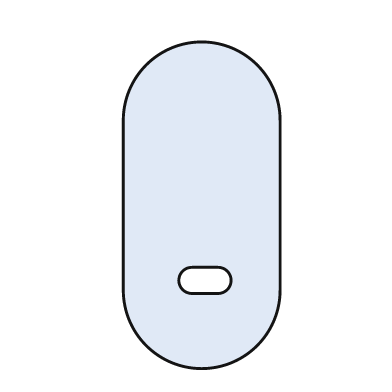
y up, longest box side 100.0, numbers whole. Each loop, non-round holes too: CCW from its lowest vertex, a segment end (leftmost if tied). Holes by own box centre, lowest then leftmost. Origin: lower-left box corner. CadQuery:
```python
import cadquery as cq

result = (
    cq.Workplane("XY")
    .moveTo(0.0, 24.0)
    .threePointArc((24.0, 0.0), (48.0, 24.0))
    .lineTo(48.0, 76.0)
    .threePointArc((24.0, 100.0), (0.0, 76.0))
    .close()
    .moveTo(21.0, 23.0)
    .lineTo(29.0, 23.0)
    .threePointArc((33.0, 27.0), (29.0, 31.0))
    .lineTo(21.0, 31.0)
    .threePointArc((17.0, 27.0), (21.0, 23.0))
    .close()
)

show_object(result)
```